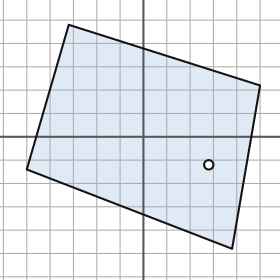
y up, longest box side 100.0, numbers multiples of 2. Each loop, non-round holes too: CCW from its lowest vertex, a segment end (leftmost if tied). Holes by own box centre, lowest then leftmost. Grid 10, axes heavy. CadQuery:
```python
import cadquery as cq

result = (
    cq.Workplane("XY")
    .moveTo(38.0, -48.0)
    .lineTo(50.0, 22.0)
    .lineTo(-32.0, 48.0)
    .lineTo(-50.0, -14.0)
    .close()
    .moveTo(28.0, -12.0)
    .circle(2.0)
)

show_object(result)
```